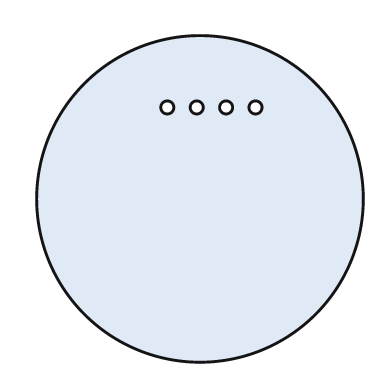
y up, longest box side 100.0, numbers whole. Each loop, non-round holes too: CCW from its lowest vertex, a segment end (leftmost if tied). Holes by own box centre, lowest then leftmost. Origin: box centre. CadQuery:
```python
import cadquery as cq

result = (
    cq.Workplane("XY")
    .moveTo(0.0, 0.0)
    .circle(50.0)
    .moveTo(-10.0, 28.0)
    .circle(2.0)
    .moveTo(-1.0, 28.0)
    .circle(2.0)
    .moveTo(8.0, 28.0)
    .circle(2.0)
    .moveTo(17.0, 28.0)
    .circle(2.0)
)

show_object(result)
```